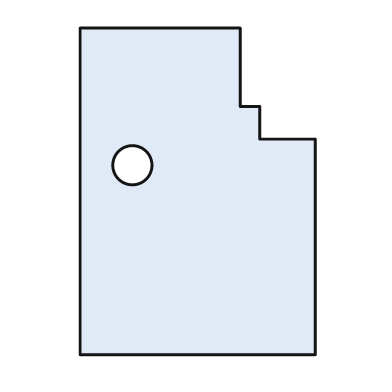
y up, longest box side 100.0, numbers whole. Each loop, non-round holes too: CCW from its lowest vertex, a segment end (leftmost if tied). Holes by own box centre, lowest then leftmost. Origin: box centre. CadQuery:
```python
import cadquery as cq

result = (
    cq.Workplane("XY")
    .moveTo(-36.0, -50.0)
    .lineTo(36.0, -50.0)
    .lineTo(36.0, 16.0)
    .lineTo(19.0, 16.0)
    .lineTo(19.0, 26.0)
    .lineTo(13.0, 26.0)
    .lineTo(13.0, 50.0)
    .lineTo(-36.0, 50.0)
    .close()
    .moveTo(-20.0, 8.0)
    .circle(6.0)
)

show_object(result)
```